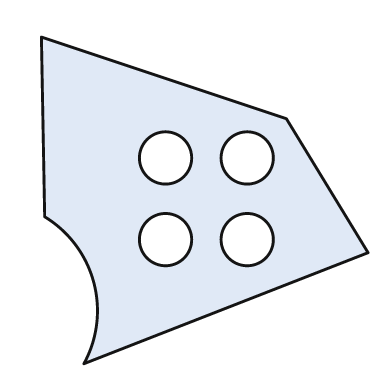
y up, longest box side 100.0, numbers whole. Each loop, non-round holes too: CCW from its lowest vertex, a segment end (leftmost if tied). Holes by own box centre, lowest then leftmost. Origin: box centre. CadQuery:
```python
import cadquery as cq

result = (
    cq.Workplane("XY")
    .moveTo(-37.0, -50.0)
    .lineTo(50.0, -16.0)
    .lineTo(25.0, 25.0)
    .lineTo(-50.0, 50.0)
    .lineTo(-49.0, -5.0)
    .threePointArc((-34.0, -25.0), (-37.0, -50.0))
    .close()
    .moveTo(-12.0, -12.0)
    .circle(8.0)
    .moveTo(13.0, -12.0)
    .circle(8.0)
    .moveTo(-12.0, 13.0)
    .circle(8.0)
    .moveTo(13.0, 13.0)
    .circle(8.0)
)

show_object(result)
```